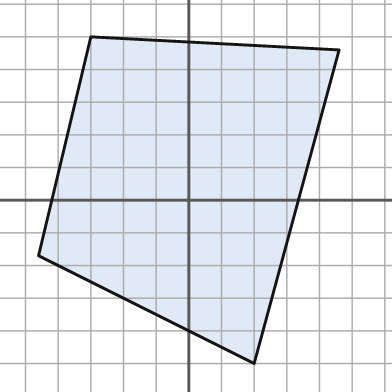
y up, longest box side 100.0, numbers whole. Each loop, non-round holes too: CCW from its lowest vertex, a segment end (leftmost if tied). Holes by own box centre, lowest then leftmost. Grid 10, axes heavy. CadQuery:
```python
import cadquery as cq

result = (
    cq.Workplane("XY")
    .moveTo(20.0, -50.0)
    .lineTo(46.0, 46.0)
    .lineTo(-30.0, 50.0)
    .lineTo(-46.0, -17.0)
    .close()
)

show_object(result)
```